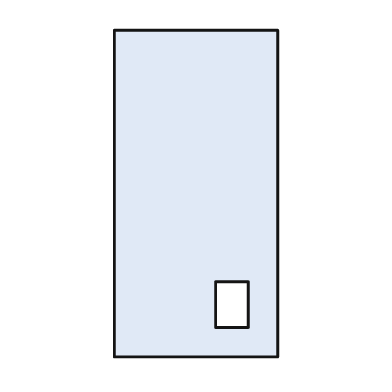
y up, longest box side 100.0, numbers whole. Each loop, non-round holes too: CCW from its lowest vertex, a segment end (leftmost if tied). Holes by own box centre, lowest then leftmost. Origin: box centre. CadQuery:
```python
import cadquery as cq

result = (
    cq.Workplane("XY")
    .moveTo(-25.0, -50.0)
    .lineTo(25.0, -50.0)
    .lineTo(25.0, 50.0)
    .lineTo(-25.0, 50.0)
    .close()
    .moveTo(6.0, -41.0)
    .lineTo(16.0, -41.0)
    .lineTo(16.0, -27.0)
    .lineTo(6.0, -27.0)
    .close()
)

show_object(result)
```